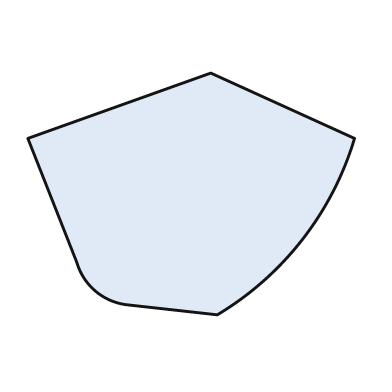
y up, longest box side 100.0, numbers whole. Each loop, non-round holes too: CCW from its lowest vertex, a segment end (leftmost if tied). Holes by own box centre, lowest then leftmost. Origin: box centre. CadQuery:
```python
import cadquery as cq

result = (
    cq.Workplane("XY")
    .moveTo(8.0, -37.0)
    .threePointArc((34.0, -14.0), (50.0, 17.0))
    .lineTo(6.0, 37.0)
    .lineTo(-50.0, 17.0)
    .lineTo(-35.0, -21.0)
    .threePointArc((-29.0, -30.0), (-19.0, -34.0))
    .close()
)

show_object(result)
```